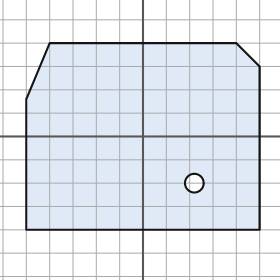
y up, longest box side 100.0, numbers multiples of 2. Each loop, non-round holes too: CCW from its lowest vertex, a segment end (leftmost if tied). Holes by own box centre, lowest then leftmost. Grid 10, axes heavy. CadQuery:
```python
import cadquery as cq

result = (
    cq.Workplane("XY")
    .moveTo(-50.0, -40.0)
    .lineTo(50.0, -40.0)
    .lineTo(50.0, 30.0)
    .lineTo(40.0, 40.0)
    .lineTo(-40.0, 40.0)
    .lineTo(-50.0, 16.0)
    .close()
    .moveTo(22.0, -20.0)
    .circle(4.0)
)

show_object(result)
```